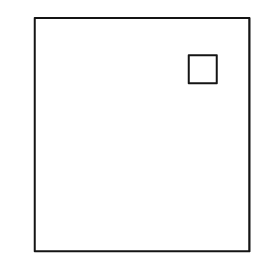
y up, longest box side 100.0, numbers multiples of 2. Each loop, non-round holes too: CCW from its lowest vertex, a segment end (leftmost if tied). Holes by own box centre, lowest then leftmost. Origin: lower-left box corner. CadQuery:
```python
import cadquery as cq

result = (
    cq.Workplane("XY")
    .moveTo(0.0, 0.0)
    .lineTo(92.0, 0.0)
    .lineTo(92.0, 100.0)
    .lineTo(0.0, 100.0)
    .close()
    .moveTo(66.0, 72.0)
    .lineTo(78.0, 72.0)
    .lineTo(78.0, 84.0)
    .lineTo(66.0, 84.0)
    .close()
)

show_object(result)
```